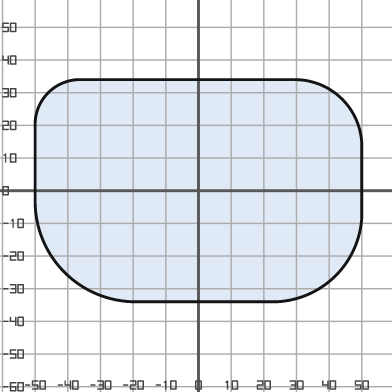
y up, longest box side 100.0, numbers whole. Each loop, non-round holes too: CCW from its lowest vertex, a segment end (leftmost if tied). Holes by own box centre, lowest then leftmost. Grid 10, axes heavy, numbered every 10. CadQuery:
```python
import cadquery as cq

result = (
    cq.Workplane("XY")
    .moveTo(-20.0, -34.0)
    .lineTo(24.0, -34.0)
    .threePointArc((42.0, -26.0), (50.0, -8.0))
    .lineTo(50.0, 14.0)
    .threePointArc((44.0, 28.0), (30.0, 34.0))
    .lineTo(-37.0, 34.0)
    .threePointArc((-46.0, 30.0), (-50.0, 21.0))
    .lineTo(-50.0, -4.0)
    .threePointArc((-41.0, -25.0), (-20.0, -34.0))
    .close()
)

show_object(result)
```